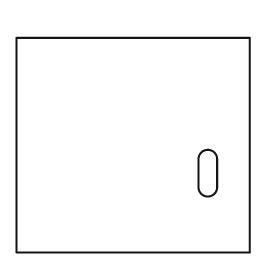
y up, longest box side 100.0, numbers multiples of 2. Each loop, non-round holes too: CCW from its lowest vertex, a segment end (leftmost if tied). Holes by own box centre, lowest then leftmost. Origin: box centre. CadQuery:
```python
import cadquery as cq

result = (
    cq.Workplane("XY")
    .moveTo(-50.0, -46.0)
    .lineTo(50.0, -46.0)
    .lineTo(50.0, 46.0)
    .lineTo(-50.0, 46.0)
    .close()
    .moveTo(28.0, -18.0)
    .threePointArc((32.0, -22.0), (36.0, -18.0))
    .lineTo(36.0, -6.0)
    .threePointArc((32.0, -2.0), (28.0, -6.0))
    .close()
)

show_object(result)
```